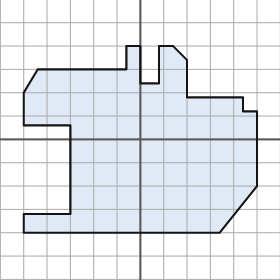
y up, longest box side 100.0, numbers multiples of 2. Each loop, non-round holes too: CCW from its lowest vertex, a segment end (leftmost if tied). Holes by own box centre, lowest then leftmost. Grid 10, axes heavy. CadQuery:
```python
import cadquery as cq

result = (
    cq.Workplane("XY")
    .moveTo(-50.0, -40.0)
    .lineTo(34.0, -40.0)
    .lineTo(50.0, -20.0)
    .lineTo(50.0, 12.0)
    .lineTo(44.0, 12.0)
    .lineTo(44.0, 18.0)
    .lineTo(20.0, 18.0)
    .lineTo(20.0, 34.0)
    .lineTo(14.0, 40.0)
    .lineTo(8.0, 40.0)
    .lineTo(8.0, 24.0)
    .lineTo(0.0, 24.0)
    .lineTo(0.0, 40.0)
    .lineTo(-6.0, 40.0)
    .lineTo(-6.0, 30.0)
    .lineTo(-44.0, 30.0)
    .lineTo(-50.0, 20.0)
    .lineTo(-50.0, 6.0)
    .lineTo(-30.0, 6.0)
    .lineTo(-30.0, -32.0)
    .lineTo(-50.0, -32.0)
    .close()
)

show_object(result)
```